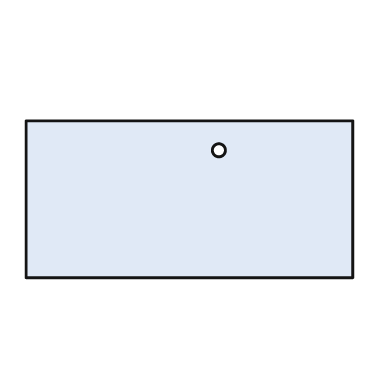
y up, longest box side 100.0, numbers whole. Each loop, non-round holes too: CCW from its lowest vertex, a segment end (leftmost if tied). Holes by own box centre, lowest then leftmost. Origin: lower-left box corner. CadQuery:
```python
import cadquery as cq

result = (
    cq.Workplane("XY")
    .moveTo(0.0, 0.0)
    .lineTo(100.0, 0.0)
    .lineTo(100.0, 48.0)
    .lineTo(0.0, 48.0)
    .close()
    .moveTo(59.0, 39.0)
    .circle(2.0)
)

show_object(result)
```